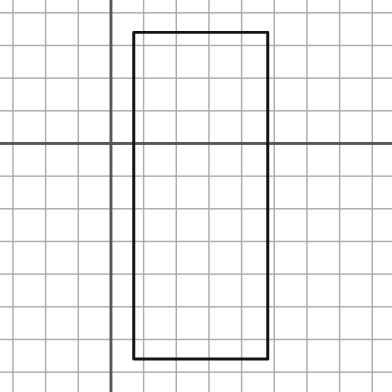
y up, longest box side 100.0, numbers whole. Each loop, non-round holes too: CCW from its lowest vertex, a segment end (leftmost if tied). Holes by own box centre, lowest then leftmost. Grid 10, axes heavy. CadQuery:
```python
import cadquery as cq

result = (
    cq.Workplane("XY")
    .moveTo(7.0, -66.0)
    .lineTo(48.0, -66.0)
    .lineTo(48.0, 34.0)
    .lineTo(7.0, 34.0)
    .close()
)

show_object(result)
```